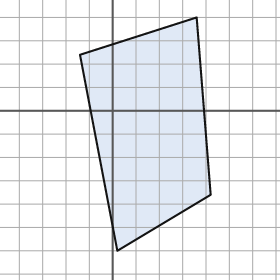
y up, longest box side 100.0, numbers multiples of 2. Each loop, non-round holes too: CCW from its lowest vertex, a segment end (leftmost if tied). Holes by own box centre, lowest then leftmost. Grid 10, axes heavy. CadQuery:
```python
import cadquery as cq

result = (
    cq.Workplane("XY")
    .moveTo(2.0, -60.0)
    .lineTo(42.0, -36.0)
    .lineTo(36.0, 40.0)
    .lineTo(-14.0, 24.0)
    .close()
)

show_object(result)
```